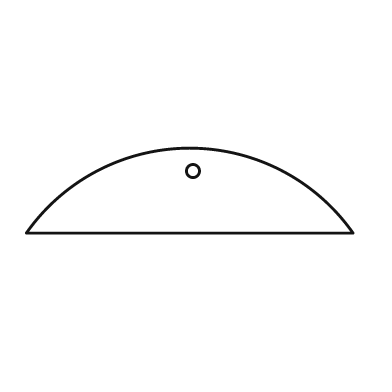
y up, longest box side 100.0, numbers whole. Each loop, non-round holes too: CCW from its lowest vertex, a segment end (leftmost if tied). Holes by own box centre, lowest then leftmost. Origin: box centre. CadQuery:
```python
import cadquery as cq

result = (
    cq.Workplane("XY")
    .moveTo(-50.0, -13.0)
    .lineTo(50.0, -13.0)
    .threePointArc((0.0, 13.0), (-50.0, -13.0))
    .close()
    .moveTo(1.0, 6.0)
    .circle(2.0)
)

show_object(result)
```